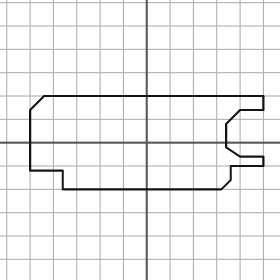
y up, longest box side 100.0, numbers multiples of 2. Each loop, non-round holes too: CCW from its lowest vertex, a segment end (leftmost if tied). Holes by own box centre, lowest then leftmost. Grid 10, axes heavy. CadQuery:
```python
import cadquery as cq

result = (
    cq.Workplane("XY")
    .moveTo(-36.0, -20.0)
    .lineTo(32.0, -20.0)
    .lineTo(36.0, -16.0)
    .lineTo(36.0, -10.0)
    .lineTo(50.0, -10.0)
    .lineTo(50.0, -6.0)
    .lineTo(40.0, -6.0)
    .lineTo(34.0, -2.0)
    .lineTo(34.0, 8.0)
    .lineTo(40.0, 14.0)
    .lineTo(50.0, 14.0)
    .lineTo(50.0, 20.0)
    .lineTo(-44.0, 20.0)
    .lineTo(-50.0, 14.0)
    .lineTo(-50.0, -12.0)
    .lineTo(-36.0, -12.0)
    .close()
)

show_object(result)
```